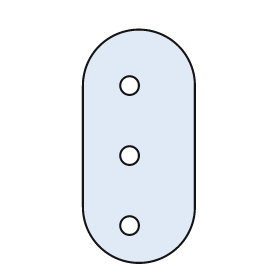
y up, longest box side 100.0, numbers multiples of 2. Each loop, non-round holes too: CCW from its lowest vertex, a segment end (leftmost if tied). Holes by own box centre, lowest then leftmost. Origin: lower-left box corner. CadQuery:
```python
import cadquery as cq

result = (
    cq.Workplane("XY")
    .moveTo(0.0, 24.0)
    .threePointArc((24.0, 0.0), (48.0, 24.0))
    .lineTo(48.0, 76.0)
    .threePointArc((24.0, 100.0), (0.0, 76.0))
    .close()
    .moveTo(20.0, 16.0)
    .circle(4.0)
    .moveTo(20.0, 46.0)
    .circle(4.0)
    .moveTo(20.0, 76.0)
    .circle(4.0)
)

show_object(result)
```